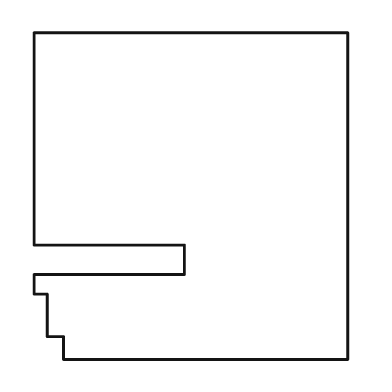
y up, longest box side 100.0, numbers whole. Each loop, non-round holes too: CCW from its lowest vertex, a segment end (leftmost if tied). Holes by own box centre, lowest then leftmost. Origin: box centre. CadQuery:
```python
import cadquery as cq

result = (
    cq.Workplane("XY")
    .moveTo(-39.0, -50.0)
    .lineTo(48.0, -50.0)
    .lineTo(48.0, 50.0)
    .lineTo(-48.0, 50.0)
    .lineTo(-48.0, -15.0)
    .lineTo(-2.0, -15.0)
    .lineTo(-2.0, -24.0)
    .lineTo(-48.0, -24.0)
    .lineTo(-48.0, -30.0)
    .lineTo(-44.0, -30.0)
    .lineTo(-44.0, -43.0)
    .lineTo(-39.0, -43.0)
    .close()
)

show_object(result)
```